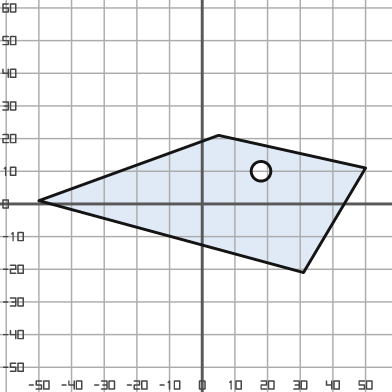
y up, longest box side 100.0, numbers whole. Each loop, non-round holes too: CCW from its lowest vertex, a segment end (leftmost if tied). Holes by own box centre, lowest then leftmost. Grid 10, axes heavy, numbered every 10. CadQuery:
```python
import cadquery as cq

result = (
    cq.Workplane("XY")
    .moveTo(31.0, -21.0)
    .lineTo(50.0, 11.0)
    .lineTo(5.0, 21.0)
    .lineTo(-50.0, 1.0)
    .close()
    .moveTo(18.0, 10.0)
    .circle(3.0)
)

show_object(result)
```